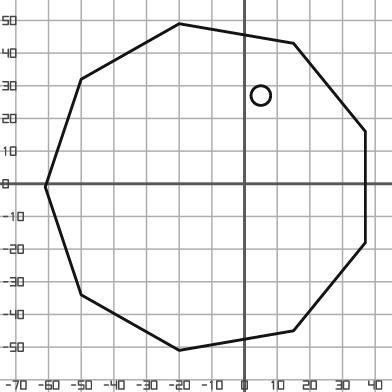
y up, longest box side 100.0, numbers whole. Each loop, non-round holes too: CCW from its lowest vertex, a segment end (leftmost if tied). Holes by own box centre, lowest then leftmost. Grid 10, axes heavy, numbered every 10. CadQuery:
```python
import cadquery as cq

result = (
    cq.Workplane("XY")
    .moveTo(-20.0, -51.0)
    .lineTo(15.0, -45.0)
    .lineTo(37.0, -18.0)
    .lineTo(37.0, 16.0)
    .lineTo(15.0, 43.0)
    .lineTo(-20.0, 49.0)
    .lineTo(-50.0, 32.0)
    .lineTo(-61.0, -1.0)
    .lineTo(-50.0, -34.0)
    .close()
    .moveTo(5.0, 27.0)
    .circle(3.0)
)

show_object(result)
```